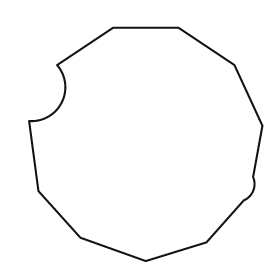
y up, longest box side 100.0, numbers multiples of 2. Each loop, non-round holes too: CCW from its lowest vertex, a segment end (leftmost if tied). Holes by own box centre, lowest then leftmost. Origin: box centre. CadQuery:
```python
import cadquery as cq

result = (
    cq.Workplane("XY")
    .moveTo(0.0, -50.0)
    .lineTo(26.0, -42.0)
    .lineTo(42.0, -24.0)
    .threePointArc((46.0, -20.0), (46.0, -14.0))
    .lineTo(50.0, 8.0)
    .lineTo(38.0, 34.0)
    .lineTo(14.0, 50.0)
    .lineTo(-14.0, 50.0)
    .lineTo(-38.0, 34.0)
    .threePointArc((-36.0, 18.0), (-50.0, 10.0))
    .lineTo(-46.0, -20.0)
    .lineTo(-28.0, -40.0)
    .close()
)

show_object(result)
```